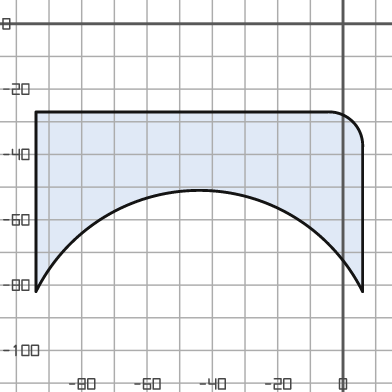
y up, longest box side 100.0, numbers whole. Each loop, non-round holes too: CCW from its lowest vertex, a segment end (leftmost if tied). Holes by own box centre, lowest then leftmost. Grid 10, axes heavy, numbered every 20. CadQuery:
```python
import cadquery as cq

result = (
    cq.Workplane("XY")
    .moveTo(-94.0, -82.0)
    .threePointArc((-44.0, -51.0), (6.0, -82.0))
    .lineTo(6.0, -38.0)
    .threePointArc((3.0, -30.0), (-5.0, -27.0))
    .lineTo(-94.0, -27.0)
    .close()
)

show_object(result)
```